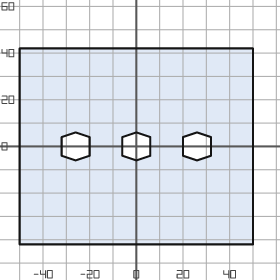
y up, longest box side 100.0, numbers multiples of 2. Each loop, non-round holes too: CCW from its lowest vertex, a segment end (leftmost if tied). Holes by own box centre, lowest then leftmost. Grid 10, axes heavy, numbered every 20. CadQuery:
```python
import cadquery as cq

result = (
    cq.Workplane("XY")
    .moveTo(-50.0, -42.0)
    .lineTo(50.0, -42.0)
    .lineTo(50.0, 42.0)
    .lineTo(-50.0, 42.0)
    .close()
    .moveTo(-26.0, -6.0)
    .lineTo(-20.0, -4.0)
    .lineTo(-20.0, 4.0)
    .lineTo(-26.0, 6.0)
    .lineTo(-32.0, 4.0)
    .lineTo(-32.0, -4.0)
    .close()
    .moveTo(0.0, -6.0)
    .lineTo(6.0, -4.0)
    .lineTo(6.0, 4.0)
    .lineTo(0.0, 6.0)
    .lineTo(-6.0, 4.0)
    .lineTo(-6.0, -4.0)
    .close()
    .moveTo(26.0, -6.0)
    .lineTo(32.0, -4.0)
    .lineTo(32.0, 4.0)
    .lineTo(26.0, 6.0)
    .lineTo(20.0, 4.0)
    .lineTo(20.0, -4.0)
    .close()
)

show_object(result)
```